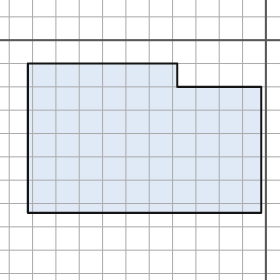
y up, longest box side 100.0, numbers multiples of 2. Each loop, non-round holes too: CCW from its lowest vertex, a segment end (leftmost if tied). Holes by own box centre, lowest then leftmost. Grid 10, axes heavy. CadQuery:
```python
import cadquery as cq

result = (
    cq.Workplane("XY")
    .moveTo(-102.0, -74.0)
    .lineTo(-2.0, -74.0)
    .lineTo(-2.0, -20.0)
    .lineTo(-38.0, -20.0)
    .lineTo(-38.0, -10.0)
    .lineTo(-102.0, -10.0)
    .close()
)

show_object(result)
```